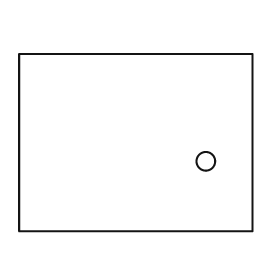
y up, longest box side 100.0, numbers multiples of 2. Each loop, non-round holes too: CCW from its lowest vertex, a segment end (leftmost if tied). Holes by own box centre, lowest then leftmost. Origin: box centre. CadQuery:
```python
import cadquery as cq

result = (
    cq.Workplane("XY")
    .moveTo(-50.0, -38.0)
    .lineTo(50.0, -38.0)
    .lineTo(50.0, 38.0)
    .lineTo(-50.0, 38.0)
    .close()
    .moveTo(30.0, -8.0)
    .circle(4.0)
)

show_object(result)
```